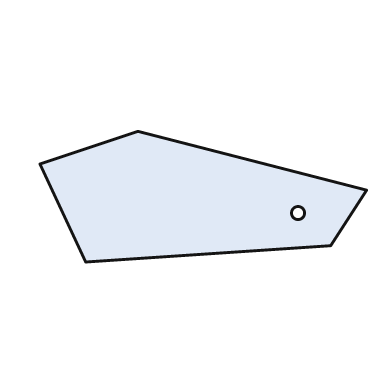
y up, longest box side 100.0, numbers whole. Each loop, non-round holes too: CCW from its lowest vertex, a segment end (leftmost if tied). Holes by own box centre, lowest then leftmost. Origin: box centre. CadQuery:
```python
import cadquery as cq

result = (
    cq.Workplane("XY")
    .moveTo(-36.0, -20.0)
    .lineTo(39.0, -15.0)
    .lineTo(50.0, 2.0)
    .lineTo(-20.0, 20.0)
    .lineTo(-50.0, 10.0)
    .close()
    .moveTo(29.0, -5.0)
    .circle(2.0)
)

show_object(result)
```